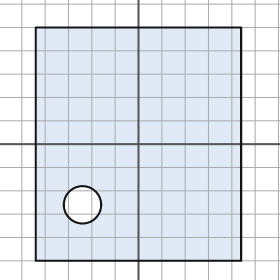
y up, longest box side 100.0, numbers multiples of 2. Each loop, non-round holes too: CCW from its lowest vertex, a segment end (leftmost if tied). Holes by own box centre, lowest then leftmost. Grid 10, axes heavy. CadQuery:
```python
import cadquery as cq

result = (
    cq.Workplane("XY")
    .moveTo(-44.0, -50.0)
    .lineTo(44.0, -50.0)
    .lineTo(44.0, 50.0)
    .lineTo(-44.0, 50.0)
    .close()
    .moveTo(-24.0, -26.0)
    .circle(8.0)
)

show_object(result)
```